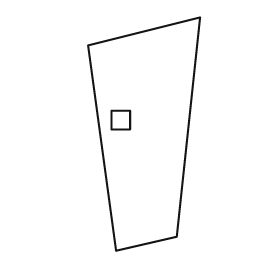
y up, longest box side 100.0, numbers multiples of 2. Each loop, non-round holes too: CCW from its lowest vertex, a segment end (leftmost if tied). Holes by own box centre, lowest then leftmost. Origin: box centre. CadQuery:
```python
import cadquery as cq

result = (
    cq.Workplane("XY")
    .moveTo(-12.0, -50.0)
    .lineTo(14.0, -44.0)
    .lineTo(24.0, 50.0)
    .lineTo(-24.0, 38.0)
    .close()
    .moveTo(-14.0, 2.0)
    .lineTo(-6.0, 2.0)
    .lineTo(-6.0, 10.0)
    .lineTo(-14.0, 10.0)
    .close()
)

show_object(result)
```